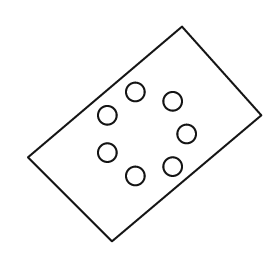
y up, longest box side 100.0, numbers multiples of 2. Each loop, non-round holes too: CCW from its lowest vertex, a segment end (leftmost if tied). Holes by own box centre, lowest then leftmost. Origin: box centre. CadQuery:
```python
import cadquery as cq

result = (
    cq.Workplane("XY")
    .moveTo(-14.0, -46.0)
    .lineTo(50.0, 8.0)
    .lineTo(16.0, 46.0)
    .lineTo(-50.0, -10.0)
    .close()
    .moveTo(-4.0, -18.0)
    .circle(4.0)
    .moveTo(12.0, -14.0)
    .circle(4.0)
    .moveTo(-16.0, -8.0)
    .circle(4.0)
    .moveTo(18.0, 0.0)
    .circle(4.0)
    .moveTo(-16.0, 8.0)
    .circle(4.0)
    .moveTo(12.0, 14.0)
    .circle(4.0)
    .moveTo(-4.0, 18.0)
    .circle(4.0)
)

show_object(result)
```